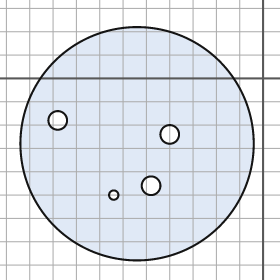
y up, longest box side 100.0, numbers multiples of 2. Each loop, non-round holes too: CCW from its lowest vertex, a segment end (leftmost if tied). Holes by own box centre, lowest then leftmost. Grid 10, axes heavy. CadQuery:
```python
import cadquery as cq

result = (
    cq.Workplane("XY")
    .moveTo(-54.0, -28.0)
    .circle(50.0)
    .moveTo(-64.0, -50.0)
    .circle(2.0)
    .moveTo(-48.0, -46.0)
    .circle(4.0)
    .moveTo(-40.0, -24.0)
    .circle(4.0)
    .moveTo(-88.0, -18.0)
    .circle(4.0)
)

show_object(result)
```